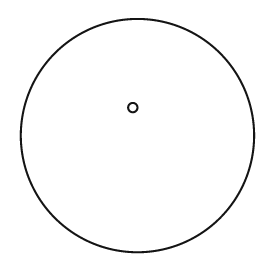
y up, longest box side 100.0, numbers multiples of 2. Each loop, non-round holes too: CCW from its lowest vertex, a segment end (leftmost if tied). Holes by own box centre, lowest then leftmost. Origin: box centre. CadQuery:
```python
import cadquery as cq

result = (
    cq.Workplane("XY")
    .moveTo(0.0, 0.0)
    .circle(50.0)
    .moveTo(-2.0, 12.0)
    .circle(2.0)
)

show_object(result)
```